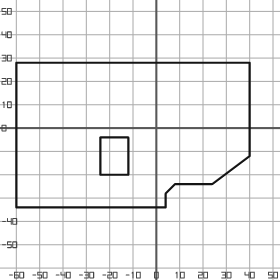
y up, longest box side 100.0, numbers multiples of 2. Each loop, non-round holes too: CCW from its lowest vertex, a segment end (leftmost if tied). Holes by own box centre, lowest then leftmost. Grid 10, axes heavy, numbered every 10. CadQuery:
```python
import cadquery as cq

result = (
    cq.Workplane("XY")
    .moveTo(-60.0, -34.0)
    .lineTo(4.0, -34.0)
    .lineTo(4.0, -28.0)
    .lineTo(8.0, -24.0)
    .lineTo(24.0, -24.0)
    .lineTo(40.0, -12.0)
    .lineTo(40.0, 28.0)
    .lineTo(-60.0, 28.0)
    .close()
    .moveTo(-24.0, -20.0)
    .lineTo(-12.0, -20.0)
    .lineTo(-12.0, -4.0)
    .lineTo(-24.0, -4.0)
    .close()
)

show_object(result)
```